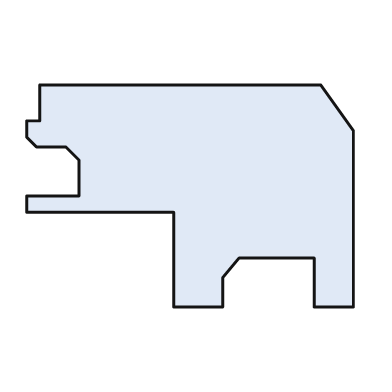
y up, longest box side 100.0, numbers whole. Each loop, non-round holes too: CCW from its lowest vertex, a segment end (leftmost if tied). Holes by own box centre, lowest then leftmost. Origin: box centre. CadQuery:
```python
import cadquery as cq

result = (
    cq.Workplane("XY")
    .moveTo(-5.0, -34.0)
    .lineTo(10.0, -34.0)
    .lineTo(10.0, -25.0)
    .lineTo(15.0, -19.0)
    .lineTo(38.0, -19.0)
    .lineTo(38.0, -34.0)
    .lineTo(50.0, -34.0)
    .lineTo(50.0, 20.0)
    .lineTo(40.0, 34.0)
    .lineTo(-46.0, 34.0)
    .lineTo(-46.0, 23.0)
    .lineTo(-50.0, 23.0)
    .lineTo(-50.0, 18.0)
    .lineTo(-47.0, 15.0)
    .lineTo(-38.0, 15.0)
    .lineTo(-34.0, 11.0)
    .lineTo(-34.0, 0.0)
    .lineTo(-50.0, 0.0)
    .lineTo(-50.0, -5.0)
    .lineTo(-5.0, -5.0)
    .close()
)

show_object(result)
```